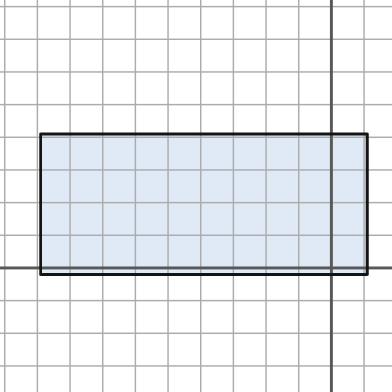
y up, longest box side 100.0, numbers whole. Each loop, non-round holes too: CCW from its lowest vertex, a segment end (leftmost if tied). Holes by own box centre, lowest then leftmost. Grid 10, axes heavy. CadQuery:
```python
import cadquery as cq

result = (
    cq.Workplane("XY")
    .moveTo(-89.0, -2.0)
    .lineTo(11.0, -2.0)
    .lineTo(11.0, 41.0)
    .lineTo(-89.0, 41.0)
    .close()
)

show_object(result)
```